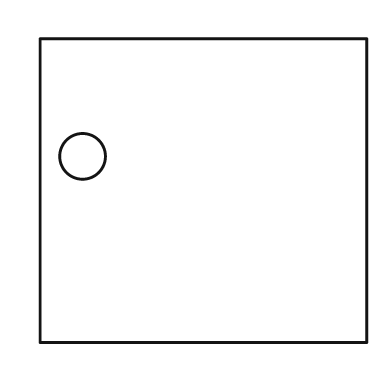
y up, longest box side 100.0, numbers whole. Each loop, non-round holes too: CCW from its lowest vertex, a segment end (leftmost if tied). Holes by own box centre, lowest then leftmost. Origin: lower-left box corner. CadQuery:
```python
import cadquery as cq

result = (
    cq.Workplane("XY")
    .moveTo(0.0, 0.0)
    .lineTo(100.0, 0.0)
    .lineTo(100.0, 93.0)
    .lineTo(0.0, 93.0)
    .close()
    .moveTo(13.0, 57.0)
    .circle(7.0)
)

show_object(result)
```